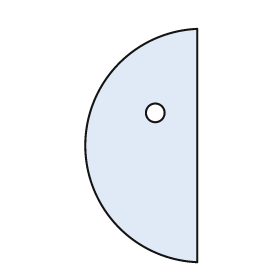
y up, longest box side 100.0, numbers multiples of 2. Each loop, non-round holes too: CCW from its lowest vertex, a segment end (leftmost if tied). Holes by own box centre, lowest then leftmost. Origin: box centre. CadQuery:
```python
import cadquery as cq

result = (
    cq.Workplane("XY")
    .moveTo(24.0, -50.0)
    .lineTo(24.0, 50.0)
    .threePointArc((-24.0, 0.0), (24.0, -50.0))
    .close()
    .moveTo(6.0, 14.0)
    .circle(4.0)
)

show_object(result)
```